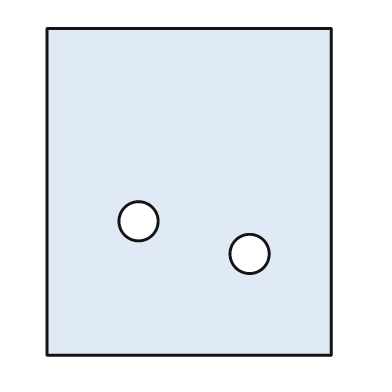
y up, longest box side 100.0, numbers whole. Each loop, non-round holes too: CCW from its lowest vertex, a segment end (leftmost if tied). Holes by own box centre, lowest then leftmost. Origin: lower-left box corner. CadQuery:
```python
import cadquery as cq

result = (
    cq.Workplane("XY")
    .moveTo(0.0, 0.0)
    .lineTo(87.0, 0.0)
    .lineTo(87.0, 100.0)
    .lineTo(0.0, 100.0)
    .close()
    .moveTo(62.0, 31.0)
    .circle(6.0)
    .moveTo(28.0, 41.0)
    .circle(6.0)
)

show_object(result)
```